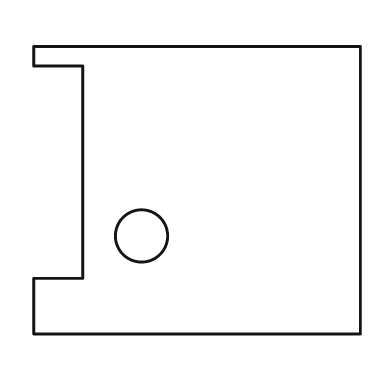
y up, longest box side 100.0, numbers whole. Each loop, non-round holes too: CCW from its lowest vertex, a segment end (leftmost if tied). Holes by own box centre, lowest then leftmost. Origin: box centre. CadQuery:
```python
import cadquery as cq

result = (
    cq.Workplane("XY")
    .moveTo(-50.0, -44.0)
    .lineTo(50.0, -44.0)
    .lineTo(50.0, 44.0)
    .lineTo(-50.0, 44.0)
    .lineTo(-50.0, 38.0)
    .lineTo(-35.0, 38.0)
    .lineTo(-35.0, -27.0)
    .lineTo(-50.0, -27.0)
    .close()
    .moveTo(-17.0, -14.0)
    .circle(8.0)
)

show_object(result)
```